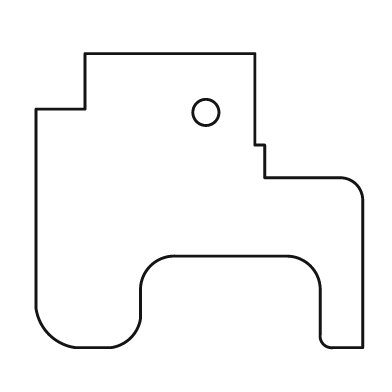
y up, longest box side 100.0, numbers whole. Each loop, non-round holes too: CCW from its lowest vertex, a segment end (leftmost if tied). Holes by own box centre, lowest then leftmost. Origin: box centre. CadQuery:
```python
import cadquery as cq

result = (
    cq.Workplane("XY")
    .moveTo(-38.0, -45.0)
    .lineTo(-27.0, -45.0)
    .threePointArc((-21.0, -42.0), (-18.0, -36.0))
    .lineTo(-18.0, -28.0)
    .threePointArc((-15.0, -20.0), (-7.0, -17.0))
    .lineTo(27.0, -17.0)
    .threePointArc((34.0, -20.0), (37.0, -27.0))
    .lineTo(37.0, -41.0)
    .threePointArc((38.0, -44.0), (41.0, -45.0))
    .lineTo(50.0, -45.0)
    .lineTo(50.0, 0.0)
    .threePointArc((48.0, 5.0), (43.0, 7.0))
    .lineTo(20.0, 7.0)
    .lineTo(20.0, 17.0)
    .lineTo(17.0, 17.0)
    .lineTo(17.0, 45.0)
    .lineTo(-35.0, 45.0)
    .lineTo(-35.0, 28.0)
    .lineTo(-50.0, 28.0)
    .lineTo(-50.0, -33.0)
    .threePointArc((-46.0, -41.0), (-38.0, -45.0))
    .close()
    .moveTo(2.0, 27.0)
    .circle(4.0)
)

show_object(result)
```